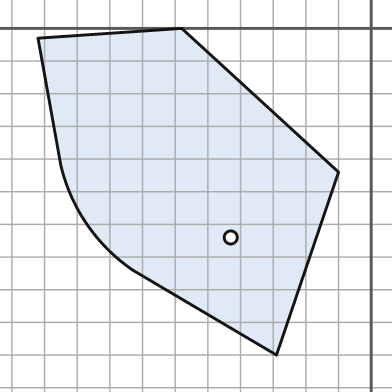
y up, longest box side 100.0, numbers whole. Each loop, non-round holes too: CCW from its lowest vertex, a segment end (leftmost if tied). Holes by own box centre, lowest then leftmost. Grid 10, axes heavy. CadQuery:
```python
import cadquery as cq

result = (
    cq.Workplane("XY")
    .moveTo(-29.0, -100.0)
    .lineTo(-10.0, -44.0)
    .lineTo(-58.0, 0.0)
    .lineTo(-102.0, -3.0)
    .lineTo(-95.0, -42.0)
    .threePointArc((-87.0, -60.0), (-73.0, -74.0))
    .close()
    .moveTo(-43.0, -64.0)
    .circle(2.0)
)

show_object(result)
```